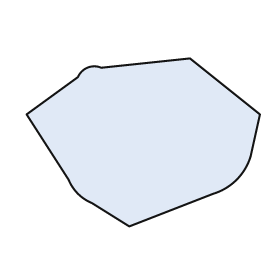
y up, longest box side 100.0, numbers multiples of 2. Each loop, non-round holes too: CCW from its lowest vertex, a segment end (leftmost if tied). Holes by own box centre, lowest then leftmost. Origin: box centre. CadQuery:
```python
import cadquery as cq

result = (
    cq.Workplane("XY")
    .moveTo(-6.0, -36.0)
    .lineTo(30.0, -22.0)
    .threePointArc((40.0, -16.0), (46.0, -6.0))
    .lineTo(50.0, 12.0)
    .lineTo(20.0, 36.0)
    .lineTo(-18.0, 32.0)
    .threePointArc((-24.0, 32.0), (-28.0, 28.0))
    .lineTo(-50.0, 12.0)
    .lineTo(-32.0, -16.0)
    .threePointArc((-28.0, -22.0), (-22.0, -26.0))
    .close()
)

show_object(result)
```